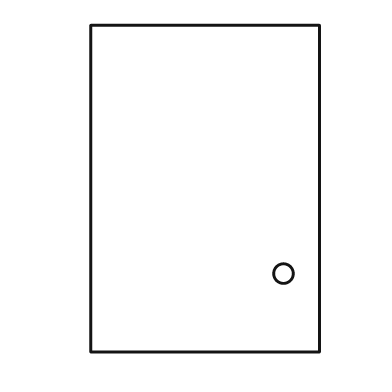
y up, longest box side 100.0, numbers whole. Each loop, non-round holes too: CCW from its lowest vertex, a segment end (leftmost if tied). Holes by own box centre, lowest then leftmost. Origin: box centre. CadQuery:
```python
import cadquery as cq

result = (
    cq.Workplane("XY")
    .moveTo(-35.0, -50.0)
    .lineTo(35.0, -50.0)
    .lineTo(35.0, 50.0)
    .lineTo(-35.0, 50.0)
    .close()
    .moveTo(24.0, -26.0)
    .circle(3.0)
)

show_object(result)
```